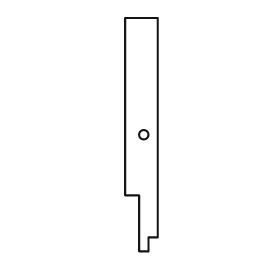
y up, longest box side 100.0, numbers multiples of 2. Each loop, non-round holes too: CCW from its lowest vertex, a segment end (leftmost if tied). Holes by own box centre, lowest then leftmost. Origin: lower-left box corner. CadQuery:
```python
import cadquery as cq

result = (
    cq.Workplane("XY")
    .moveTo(6.0, 0.0)
    .lineTo(10.0, 0.0)
    .lineTo(10.0, 6.0)
    .lineTo(14.0, 6.0)
    .lineTo(14.0, 100.0)
    .lineTo(0.0, 100.0)
    .lineTo(0.0, 24.0)
    .lineTo(6.0, 24.0)
    .close()
    .moveTo(8.0, 50.0)
    .circle(2.0)
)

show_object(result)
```